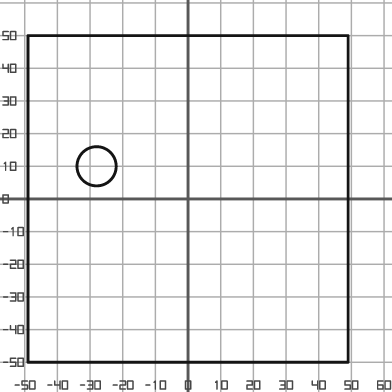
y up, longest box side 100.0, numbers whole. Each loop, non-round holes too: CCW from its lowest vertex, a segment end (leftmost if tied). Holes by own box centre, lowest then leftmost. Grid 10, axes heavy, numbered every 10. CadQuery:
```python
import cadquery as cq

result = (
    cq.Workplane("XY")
    .moveTo(-49.0, -50.0)
    .lineTo(49.0, -50.0)
    .lineTo(49.0, 50.0)
    .lineTo(-49.0, 50.0)
    .close()
    .moveTo(-28.0, 10.0)
    .circle(6.0)
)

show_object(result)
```